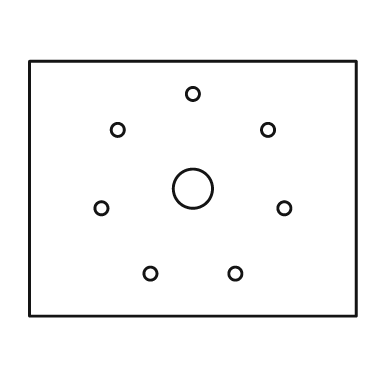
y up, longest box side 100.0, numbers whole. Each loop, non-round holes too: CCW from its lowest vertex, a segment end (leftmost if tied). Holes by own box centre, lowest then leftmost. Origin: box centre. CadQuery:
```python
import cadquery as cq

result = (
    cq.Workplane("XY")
    .moveTo(-50.0, -39.0)
    .lineTo(50.0, -39.0)
    .lineTo(50.0, 39.0)
    .lineTo(-50.0, 39.0)
    .close()
    .moveTo(-13.0, -26.0)
    .circle(2.0)
    .moveTo(13.0, -26.0)
    .circle(2.0)
    .moveTo(-28.0, -6.0)
    .circle(2.0)
    .moveTo(28.0, -6.0)
    .circle(2.0)
    .moveTo(0.0, 0.0)
    .circle(6.0)
    .moveTo(-23.0, 18.0)
    .circle(2.0)
    .moveTo(23.0, 18.0)
    .circle(2.0)
    .moveTo(0.0, 29.0)
    .circle(2.0)
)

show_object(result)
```